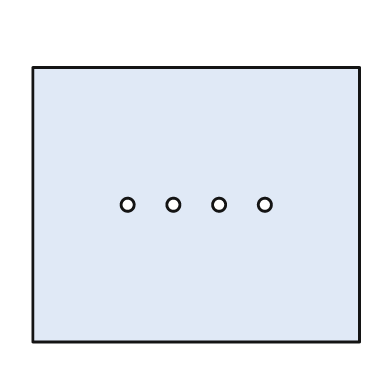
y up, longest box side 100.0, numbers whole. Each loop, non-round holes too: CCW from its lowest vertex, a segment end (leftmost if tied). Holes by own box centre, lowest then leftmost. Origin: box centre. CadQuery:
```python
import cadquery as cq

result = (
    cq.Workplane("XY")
    .moveTo(-50.0, -42.0)
    .lineTo(50.0, -42.0)
    .lineTo(50.0, 42.0)
    .lineTo(-50.0, 42.0)
    .close()
    .moveTo(-21.0, 0.0)
    .circle(2.0)
    .moveTo(-7.0, 0.0)
    .circle(2.0)
    .moveTo(7.0, 0.0)
    .circle(2.0)
    .moveTo(21.0, 0.0)
    .circle(2.0)
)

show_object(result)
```